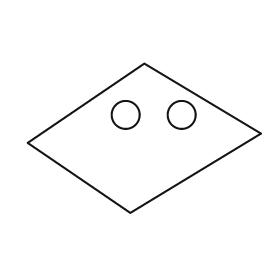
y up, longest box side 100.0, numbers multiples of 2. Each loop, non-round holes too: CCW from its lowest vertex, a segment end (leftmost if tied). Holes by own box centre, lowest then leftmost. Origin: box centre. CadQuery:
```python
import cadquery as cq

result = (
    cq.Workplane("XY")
    .moveTo(-6.0, -32.0)
    .lineTo(50.0, 2.0)
    .lineTo(0.0, 32.0)
    .lineTo(-50.0, -2.0)
    .close()
    .moveTo(-8.0, 10.0)
    .circle(6.0)
    .moveTo(16.0, 10.0)
    .circle(6.0)
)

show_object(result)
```